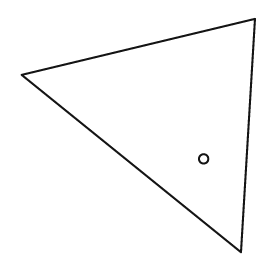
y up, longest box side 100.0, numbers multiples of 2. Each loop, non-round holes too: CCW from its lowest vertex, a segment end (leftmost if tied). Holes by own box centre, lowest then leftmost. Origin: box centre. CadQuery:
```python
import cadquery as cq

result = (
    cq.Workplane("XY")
    .moveTo(44.0, -50.0)
    .lineTo(50.0, 50.0)
    .lineTo(-50.0, 26.0)
    .close()
    .moveTo(28.0, -10.0)
    .circle(2.0)
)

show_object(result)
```